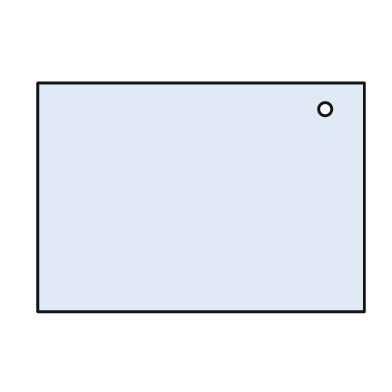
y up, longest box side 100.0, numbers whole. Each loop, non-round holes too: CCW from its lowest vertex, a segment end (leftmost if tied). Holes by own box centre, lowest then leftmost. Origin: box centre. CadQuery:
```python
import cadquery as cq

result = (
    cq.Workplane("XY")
    .moveTo(-50.0, -35.0)
    .lineTo(50.0, -35.0)
    .lineTo(50.0, 35.0)
    .lineTo(-50.0, 35.0)
    .close()
    .moveTo(38.0, 27.0)
    .circle(2.0)
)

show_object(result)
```